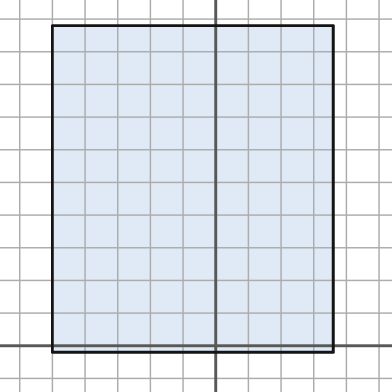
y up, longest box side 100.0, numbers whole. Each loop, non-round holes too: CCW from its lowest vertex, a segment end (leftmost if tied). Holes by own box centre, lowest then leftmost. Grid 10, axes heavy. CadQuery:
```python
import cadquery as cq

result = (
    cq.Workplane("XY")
    .moveTo(-50.0, -2.0)
    .lineTo(36.0, -2.0)
    .lineTo(36.0, 98.0)
    .lineTo(-50.0, 98.0)
    .close()
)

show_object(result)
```